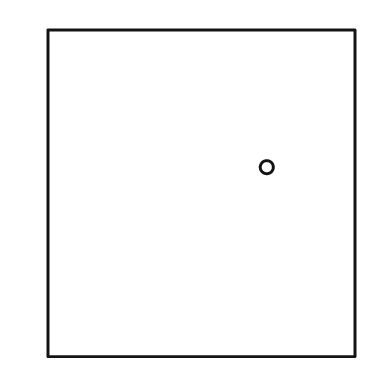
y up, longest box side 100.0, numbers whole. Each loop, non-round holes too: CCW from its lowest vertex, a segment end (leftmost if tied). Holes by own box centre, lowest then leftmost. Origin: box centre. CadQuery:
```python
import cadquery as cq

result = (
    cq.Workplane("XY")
    .moveTo(-47.0, -50.0)
    .lineTo(47.0, -50.0)
    .lineTo(47.0, 50.0)
    .lineTo(-47.0, 50.0)
    .close()
    .moveTo(20.0, 8.0)
    .circle(2.0)
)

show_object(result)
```